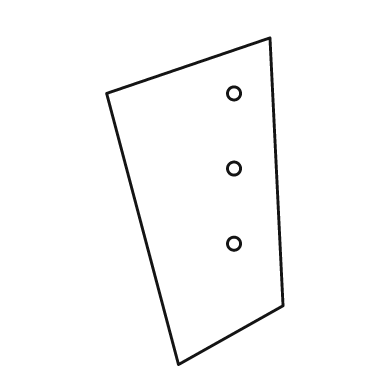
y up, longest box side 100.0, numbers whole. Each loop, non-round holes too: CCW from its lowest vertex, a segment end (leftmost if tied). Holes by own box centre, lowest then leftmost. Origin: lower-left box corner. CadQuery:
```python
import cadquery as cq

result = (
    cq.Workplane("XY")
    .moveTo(22.0, 0.0)
    .lineTo(54.0, 18.0)
    .lineTo(50.0, 100.0)
    .lineTo(0.0, 83.0)
    .close()
    .moveTo(39.0, 37.0)
    .circle(2.0)
    .moveTo(39.0, 60.0)
    .circle(2.0)
    .moveTo(39.0, 83.0)
    .circle(2.0)
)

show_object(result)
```